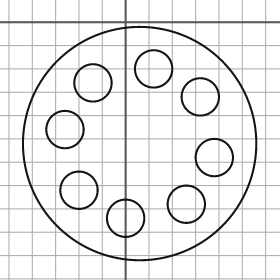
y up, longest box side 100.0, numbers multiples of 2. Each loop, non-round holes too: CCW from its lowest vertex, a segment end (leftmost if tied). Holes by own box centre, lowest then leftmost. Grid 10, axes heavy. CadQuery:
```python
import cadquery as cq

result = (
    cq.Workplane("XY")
    .moveTo(6.0, -52.0)
    .circle(50.0)
    .moveTo(0.0, -84.0)
    .circle(8.0)
    .moveTo(26.0, -78.0)
    .circle(8.0)
    .moveTo(-20.0, -72.0)
    .circle(8.0)
    .moveTo(38.0, -58.0)
    .circle(8.0)
    .moveTo(-26.0, -46.0)
    .circle(8.0)
    .moveTo(32.0, -32.0)
    .circle(8.0)
    .moveTo(-14.0, -26.0)
    .circle(8.0)
    .moveTo(12.0, -20.0)
    .circle(8.0)
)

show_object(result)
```